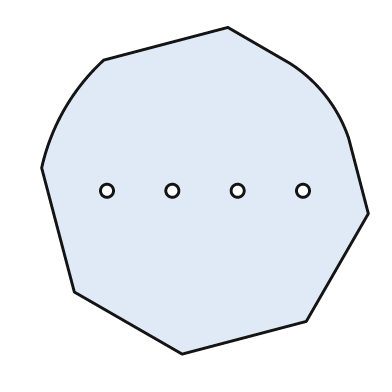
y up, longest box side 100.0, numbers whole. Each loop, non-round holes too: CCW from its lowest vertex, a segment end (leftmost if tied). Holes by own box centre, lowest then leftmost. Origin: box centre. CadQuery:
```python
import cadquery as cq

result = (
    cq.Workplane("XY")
    .moveTo(-7.0, -50.0)
    .lineTo(31.0, -40.0)
    .lineTo(50.0, -7.0)
    .lineTo(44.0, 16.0)
    .threePointArc((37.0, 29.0), (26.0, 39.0))
    .lineTo(7.0, 50.0)
    .lineTo(-31.0, 40.0)
    .threePointArc((-43.0, 25.0), (-50.0, 7.0))
    .lineTo(-40.0, -31.0)
    .close()
    .moveTo(-30.0, 0.0)
    .circle(2.0)
    .moveTo(-10.0, 0.0)
    .circle(2.0)
    .moveTo(10.0, 0.0)
    .circle(2.0)
    .moveTo(30.0, 0.0)
    .circle(2.0)
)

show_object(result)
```